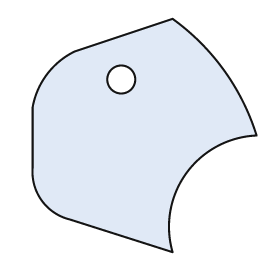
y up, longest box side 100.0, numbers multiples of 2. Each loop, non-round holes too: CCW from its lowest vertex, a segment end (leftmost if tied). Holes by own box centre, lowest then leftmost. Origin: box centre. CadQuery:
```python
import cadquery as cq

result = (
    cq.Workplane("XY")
    .moveTo(12.0, -50.0)
    .threePointArc((18.0, -16.0), (48.0, 0.0))
    .threePointArc((34.0, 28.0), (12.0, 50.0))
    .lineTo(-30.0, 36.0)
    .threePointArc((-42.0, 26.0), (-48.0, 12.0))
    .lineTo(-48.0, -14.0)
    .threePointArc((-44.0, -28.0), (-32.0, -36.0))
    .close()
    .moveTo(-10.0, 24.0)
    .circle(6.0)
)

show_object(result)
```